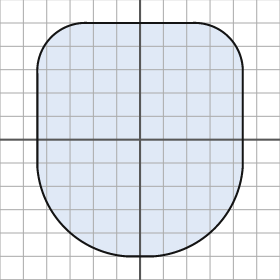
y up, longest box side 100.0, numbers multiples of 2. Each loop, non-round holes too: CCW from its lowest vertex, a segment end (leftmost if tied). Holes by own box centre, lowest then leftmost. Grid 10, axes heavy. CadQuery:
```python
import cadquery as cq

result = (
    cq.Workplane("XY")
    .moveTo(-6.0, -50.0)
    .lineTo(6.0, -50.0)
    .threePointArc((32.0, -38.0), (44.0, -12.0))
    .lineTo(44.0, 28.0)
    .threePointArc((38.0, 44.0), (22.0, 50.0))
    .lineTo(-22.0, 50.0)
    .threePointArc((-38.0, 44.0), (-44.0, 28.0))
    .lineTo(-44.0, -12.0)
    .threePointArc((-32.0, -38.0), (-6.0, -50.0))
    .close()
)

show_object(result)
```